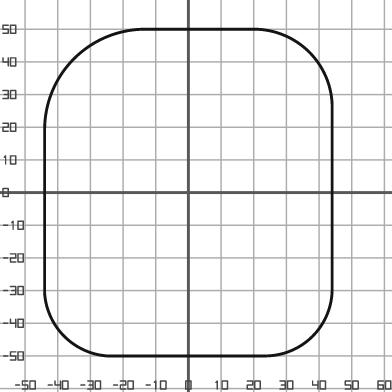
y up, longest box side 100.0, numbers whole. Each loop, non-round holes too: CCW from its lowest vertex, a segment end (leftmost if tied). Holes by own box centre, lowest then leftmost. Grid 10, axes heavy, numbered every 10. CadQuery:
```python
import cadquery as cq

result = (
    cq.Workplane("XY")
    .moveTo(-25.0, -50.0)
    .lineTo(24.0, -50.0)
    .threePointArc((38.0, -44.0), (44.0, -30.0))
    .lineTo(44.0, 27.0)
    .threePointArc((37.0, 43.0), (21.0, 50.0))
    .lineTo(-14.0, 50.0)
    .threePointArc((-35.0, 41.0), (-44.0, 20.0))
    .lineTo(-44.0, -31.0)
    .threePointArc((-38.0, -44.0), (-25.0, -50.0))
    .close()
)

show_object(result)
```